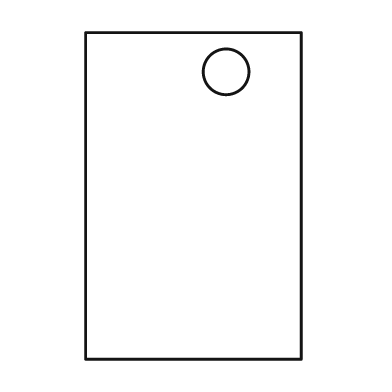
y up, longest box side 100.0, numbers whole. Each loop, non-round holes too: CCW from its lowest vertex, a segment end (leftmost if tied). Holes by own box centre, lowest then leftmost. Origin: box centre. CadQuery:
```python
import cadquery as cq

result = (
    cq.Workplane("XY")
    .moveTo(-33.0, -50.0)
    .lineTo(33.0, -50.0)
    .lineTo(33.0, 50.0)
    .lineTo(-33.0, 50.0)
    .close()
    .moveTo(10.0, 38.0)
    .circle(7.0)
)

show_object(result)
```